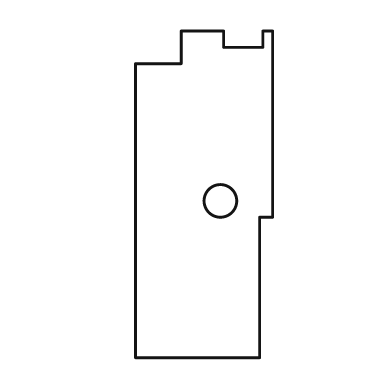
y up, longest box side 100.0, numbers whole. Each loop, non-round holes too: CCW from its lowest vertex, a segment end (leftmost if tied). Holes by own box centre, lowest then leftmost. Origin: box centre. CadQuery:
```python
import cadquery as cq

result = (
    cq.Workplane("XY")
    .moveTo(-21.0, -50.0)
    .lineTo(17.0, -50.0)
    .lineTo(17.0, -7.0)
    .lineTo(21.0, -7.0)
    .lineTo(21.0, 50.0)
    .lineTo(18.0, 50.0)
    .lineTo(18.0, 45.0)
    .lineTo(6.0, 45.0)
    .lineTo(6.0, 50.0)
    .lineTo(-7.0, 50.0)
    .lineTo(-7.0, 40.0)
    .lineTo(-21.0, 40.0)
    .close()
    .moveTo(5.0, -2.0)
    .circle(5.0)
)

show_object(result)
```